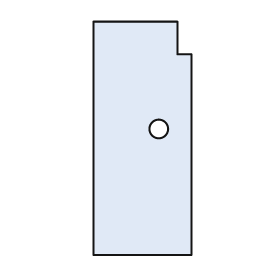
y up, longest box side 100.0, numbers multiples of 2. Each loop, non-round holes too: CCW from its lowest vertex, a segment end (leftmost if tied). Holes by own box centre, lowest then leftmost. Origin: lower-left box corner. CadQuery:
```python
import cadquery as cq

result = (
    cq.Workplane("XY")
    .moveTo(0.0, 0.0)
    .lineTo(42.0, 0.0)
    .lineTo(42.0, 86.0)
    .lineTo(36.0, 86.0)
    .lineTo(36.0, 100.0)
    .lineTo(0.0, 100.0)
    .close()
    .moveTo(28.0, 54.0)
    .circle(4.0)
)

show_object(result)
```